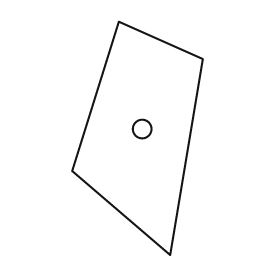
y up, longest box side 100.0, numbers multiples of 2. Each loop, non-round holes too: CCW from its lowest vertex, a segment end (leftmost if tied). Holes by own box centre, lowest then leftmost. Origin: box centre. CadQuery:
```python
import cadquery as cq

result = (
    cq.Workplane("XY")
    .moveTo(14.0, -50.0)
    .lineTo(28.0, 34.0)
    .lineTo(-8.0, 50.0)
    .lineTo(-28.0, -14.0)
    .close()
    .moveTo(2.0, 4.0)
    .circle(4.0)
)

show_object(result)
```